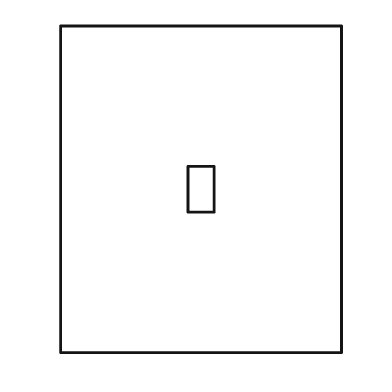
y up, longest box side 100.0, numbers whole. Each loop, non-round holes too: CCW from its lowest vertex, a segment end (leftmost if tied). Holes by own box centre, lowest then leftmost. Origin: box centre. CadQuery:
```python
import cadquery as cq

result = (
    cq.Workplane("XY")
    .moveTo(-43.0, -50.0)
    .lineTo(43.0, -50.0)
    .lineTo(43.0, 50.0)
    .lineTo(-43.0, 50.0)
    .close()
    .moveTo(-4.0, -7.0)
    .lineTo(4.0, -7.0)
    .lineTo(4.0, 7.0)
    .lineTo(-4.0, 7.0)
    .close()
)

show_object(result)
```